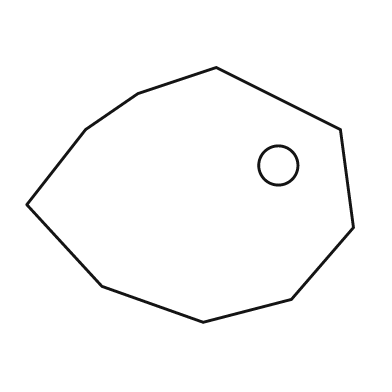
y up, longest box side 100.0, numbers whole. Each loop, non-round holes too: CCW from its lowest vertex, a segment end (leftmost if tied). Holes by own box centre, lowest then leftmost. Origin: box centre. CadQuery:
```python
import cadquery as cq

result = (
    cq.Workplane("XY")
    .moveTo(4.0, -39.0)
    .lineTo(31.0, -32.0)
    .lineTo(50.0, -10.0)
    .lineTo(46.0, 20.0)
    .lineTo(8.0, 39.0)
    .lineTo(-16.0, 31.0)
    .lineTo(-32.0, 20.0)
    .lineTo(-50.0, -3.0)
    .lineTo(-27.0, -28.0)
    .close()
    .moveTo(27.0, 9.0)
    .circle(6.0)
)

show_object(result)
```